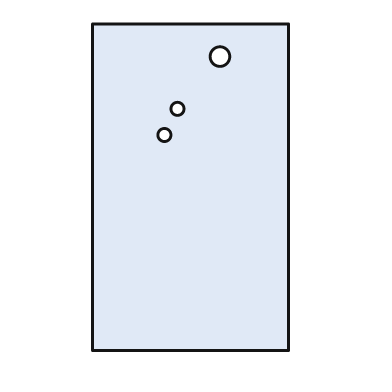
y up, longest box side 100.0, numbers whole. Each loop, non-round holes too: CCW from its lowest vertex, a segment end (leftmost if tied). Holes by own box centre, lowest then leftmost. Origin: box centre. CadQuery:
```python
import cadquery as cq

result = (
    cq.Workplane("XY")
    .moveTo(-30.0, -50.0)
    .lineTo(30.0, -50.0)
    .lineTo(30.0, 50.0)
    .lineTo(-30.0, 50.0)
    .close()
    .moveTo(-8.0, 16.0)
    .circle(2.0)
    .moveTo(-4.0, 24.0)
    .circle(2.0)
    .moveTo(9.0, 40.0)
    .circle(3.0)
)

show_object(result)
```